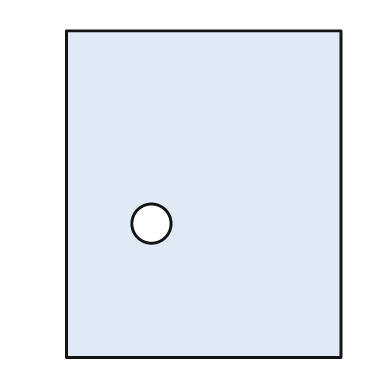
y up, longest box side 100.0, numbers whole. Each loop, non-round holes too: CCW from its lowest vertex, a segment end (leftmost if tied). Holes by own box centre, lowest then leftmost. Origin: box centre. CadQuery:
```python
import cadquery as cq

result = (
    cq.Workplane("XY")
    .moveTo(-42.0, -50.0)
    .lineTo(42.0, -50.0)
    .lineTo(42.0, 50.0)
    .lineTo(-42.0, 50.0)
    .close()
    .moveTo(-16.0, -9.0)
    .circle(6.0)
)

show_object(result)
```